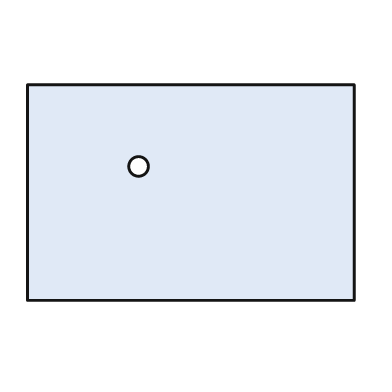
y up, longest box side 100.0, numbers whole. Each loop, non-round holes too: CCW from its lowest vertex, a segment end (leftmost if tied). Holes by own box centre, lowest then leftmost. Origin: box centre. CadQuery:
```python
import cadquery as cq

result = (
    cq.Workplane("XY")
    .moveTo(-50.0, -33.0)
    .lineTo(50.0, -33.0)
    .lineTo(50.0, 33.0)
    .lineTo(-50.0, 33.0)
    .close()
    .moveTo(-16.0, 8.0)
    .circle(3.0)
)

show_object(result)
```